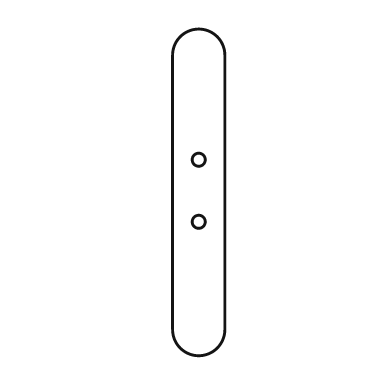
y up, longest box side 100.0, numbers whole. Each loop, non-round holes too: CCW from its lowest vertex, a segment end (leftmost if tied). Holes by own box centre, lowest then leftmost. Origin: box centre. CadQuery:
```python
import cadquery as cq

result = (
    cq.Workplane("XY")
    .moveTo(-8.0, -42.0)
    .threePointArc((0.0, -50.0), (8.0, -42.0))
    .lineTo(8.0, 42.0)
    .threePointArc((0.0, 50.0), (-8.0, 42.0))
    .close()
    .moveTo(0.0, -9.0)
    .circle(2.0)
    .moveTo(0.0, 10.0)
    .circle(2.0)
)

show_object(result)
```